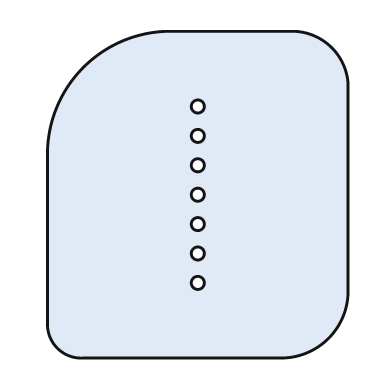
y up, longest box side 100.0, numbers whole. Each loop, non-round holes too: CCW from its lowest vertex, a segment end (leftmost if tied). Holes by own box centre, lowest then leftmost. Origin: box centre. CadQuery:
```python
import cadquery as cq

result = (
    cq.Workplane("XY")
    .moveTo(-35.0, -50.0)
    .lineTo(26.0, -50.0)
    .threePointArc((40.0, -44.0), (46.0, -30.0))
    .lineTo(46.0, 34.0)
    .threePointArc((41.0, 45.0), (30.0, 50.0))
    .lineTo(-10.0, 50.0)
    .threePointArc((-35.0, 39.0), (-46.0, 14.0))
    .lineTo(-46.0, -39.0)
    .threePointArc((-43.0, -47.0), (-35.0, -50.0))
    .close()
    .moveTo(0.0, -27.0)
    .circle(2.0)
    .moveTo(0.0, -18.0)
    .circle(2.0)
    .moveTo(0.0, -9.0)
    .circle(2.0)
    .moveTo(0.0, 0.0)
    .circle(2.0)
    .moveTo(0.0, 9.0)
    .circle(2.0)
    .moveTo(0.0, 18.0)
    .circle(2.0)
    .moveTo(0.0, 27.0)
    .circle(2.0)
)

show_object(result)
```